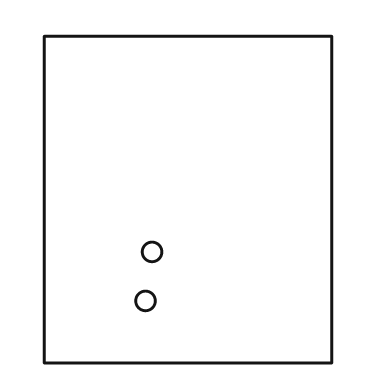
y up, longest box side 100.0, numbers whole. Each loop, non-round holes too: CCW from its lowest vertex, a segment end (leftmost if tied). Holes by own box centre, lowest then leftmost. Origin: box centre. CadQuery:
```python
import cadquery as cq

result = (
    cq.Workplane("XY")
    .moveTo(-44.0, -50.0)
    .lineTo(44.0, -50.0)
    .lineTo(44.0, 50.0)
    .lineTo(-44.0, 50.0)
    .close()
    .moveTo(-13.0, -31.0)
    .circle(3.0)
    .moveTo(-11.0, -16.0)
    .circle(3.0)
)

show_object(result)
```